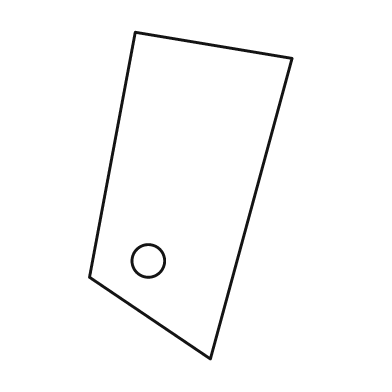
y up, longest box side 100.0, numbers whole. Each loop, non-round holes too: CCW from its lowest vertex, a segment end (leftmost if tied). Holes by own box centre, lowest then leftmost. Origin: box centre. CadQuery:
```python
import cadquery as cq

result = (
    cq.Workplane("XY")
    .moveTo(6.0, -50.0)
    .lineTo(31.0, 42.0)
    .lineTo(-17.0, 50.0)
    .lineTo(-31.0, -25.0)
    .close()
    .moveTo(-13.0, -20.0)
    .circle(5.0)
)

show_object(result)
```